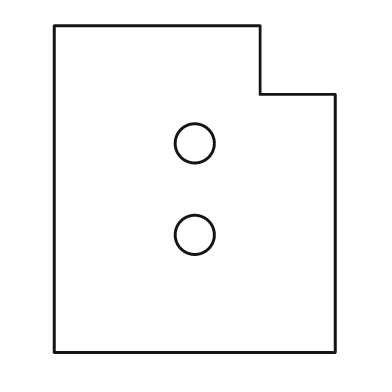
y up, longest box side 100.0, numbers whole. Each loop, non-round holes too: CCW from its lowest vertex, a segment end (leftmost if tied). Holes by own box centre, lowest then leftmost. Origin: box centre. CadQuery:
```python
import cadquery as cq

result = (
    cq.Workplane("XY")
    .moveTo(-43.0, -50.0)
    .lineTo(43.0, -50.0)
    .lineTo(43.0, 29.0)
    .lineTo(20.0, 29.0)
    .lineTo(20.0, 50.0)
    .lineTo(-43.0, 50.0)
    .close()
    .moveTo(0.0, -14.0)
    .circle(6.0)
    .moveTo(0.0, 14.0)
    .circle(6.0)
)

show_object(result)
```